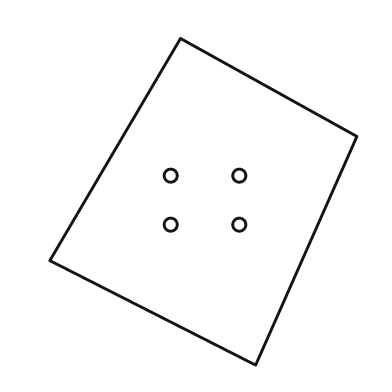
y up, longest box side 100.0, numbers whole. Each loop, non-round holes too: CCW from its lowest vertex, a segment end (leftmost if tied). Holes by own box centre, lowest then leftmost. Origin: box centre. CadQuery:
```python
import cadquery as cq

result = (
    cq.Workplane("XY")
    .moveTo(16.0, -50.0)
    .lineTo(47.0, 20.0)
    .lineTo(-7.0, 50.0)
    .lineTo(-47.0, -18.0)
    .close()
    .moveTo(-10.0, -7.0)
    .circle(2.0)
    .moveTo(11.0, -7.0)
    .circle(2.0)
    .moveTo(-10.0, 8.0)
    .circle(2.0)
    .moveTo(11.0, 8.0)
    .circle(2.0)
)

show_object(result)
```